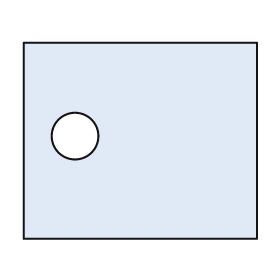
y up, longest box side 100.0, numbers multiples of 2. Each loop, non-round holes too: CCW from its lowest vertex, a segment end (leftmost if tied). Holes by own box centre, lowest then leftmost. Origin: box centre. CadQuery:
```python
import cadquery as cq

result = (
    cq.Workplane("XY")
    .moveTo(-50.0, -42.0)
    .lineTo(50.0, -42.0)
    .lineTo(50.0, 42.0)
    .lineTo(-50.0, 42.0)
    .close()
    .moveTo(-28.0, 2.0)
    .circle(10.0)
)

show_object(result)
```